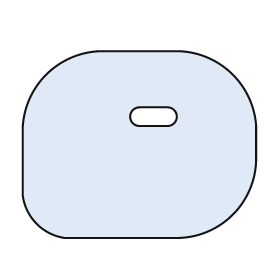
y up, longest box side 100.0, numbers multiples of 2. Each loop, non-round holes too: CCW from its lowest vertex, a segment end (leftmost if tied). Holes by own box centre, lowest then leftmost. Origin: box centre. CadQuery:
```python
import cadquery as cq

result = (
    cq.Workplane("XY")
    .moveTo(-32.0, -40.0)
    .lineTo(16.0, -40.0)
    .threePointArc((40.0, -30.0), (50.0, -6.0))
    .lineTo(50.0, 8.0)
    .threePointArc((40.0, 30.0), (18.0, 40.0))
    .lineTo(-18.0, 40.0)
    .threePointArc((-40.0, 30.0), (-50.0, 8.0))
    .lineTo(-50.0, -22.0)
    .threePointArc((-44.0, -34.0), (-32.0, -40.0))
    .close()
    .moveTo(0.0, 8.0)
    .lineTo(12.0, 8.0)
    .threePointArc((16.0, 12.0), (12.0, 16.0))
    .lineTo(0.0, 16.0)
    .threePointArc((-4.0, 12.0), (0.0, 8.0))
    .close()
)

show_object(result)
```